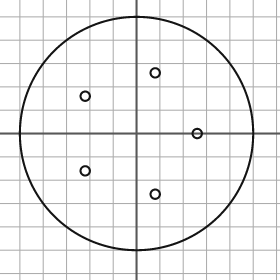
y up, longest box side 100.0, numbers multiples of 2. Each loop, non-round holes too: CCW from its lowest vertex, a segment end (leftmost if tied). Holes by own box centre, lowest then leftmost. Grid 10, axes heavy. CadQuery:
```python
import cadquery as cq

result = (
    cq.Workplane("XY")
    .moveTo(0.0, 0.0)
    .circle(50.0)
    .moveTo(8.0, -26.0)
    .circle(2.0)
    .moveTo(-22.0, -16.0)
    .circle(2.0)
    .moveTo(26.0, 0.0)
    .circle(2.0)
    .moveTo(-22.0, 16.0)
    .circle(2.0)
    .moveTo(8.0, 26.0)
    .circle(2.0)
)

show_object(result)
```